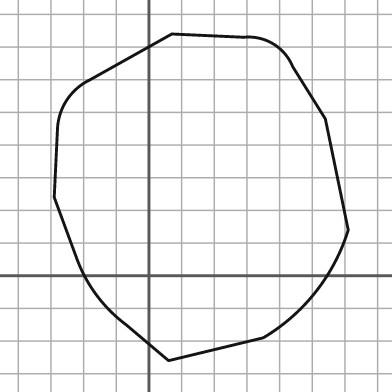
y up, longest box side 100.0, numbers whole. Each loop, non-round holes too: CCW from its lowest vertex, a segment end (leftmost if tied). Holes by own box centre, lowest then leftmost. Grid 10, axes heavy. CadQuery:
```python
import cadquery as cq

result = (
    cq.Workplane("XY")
    .moveTo(6.0, -26.0)
    .lineTo(35.0, -19.0)
    .threePointArc((51.0, -5.0), (61.0, 14.0))
    .lineTo(54.0, 48.0)
    .lineTo(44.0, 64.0)
    .threePointArc((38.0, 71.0), (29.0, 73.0))
    .lineTo(7.0, 74.0)
    .lineTo(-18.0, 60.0)
    .threePointArc((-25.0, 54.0), (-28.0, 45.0))
    .lineTo(-29.0, 24.0)
    .lineTo(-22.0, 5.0)
    .threePointArc((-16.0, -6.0), (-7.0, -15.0))
    .close()
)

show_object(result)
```